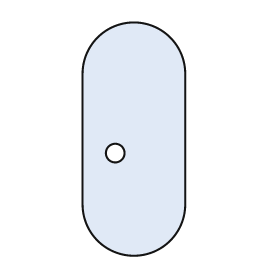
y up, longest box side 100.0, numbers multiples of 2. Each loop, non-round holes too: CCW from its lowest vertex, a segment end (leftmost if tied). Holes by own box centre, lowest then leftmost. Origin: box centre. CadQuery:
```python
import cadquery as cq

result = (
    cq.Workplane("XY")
    .moveTo(-22.0, -28.0)
    .threePointArc((0.0, -50.0), (22.0, -28.0))
    .lineTo(22.0, 28.0)
    .threePointArc((0.0, 50.0), (-22.0, 28.0))
    .close()
    .moveTo(-8.0, -6.0)
    .circle(4.0)
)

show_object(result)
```